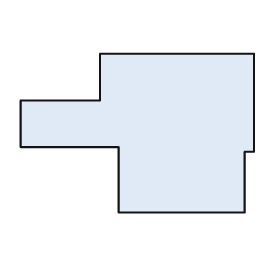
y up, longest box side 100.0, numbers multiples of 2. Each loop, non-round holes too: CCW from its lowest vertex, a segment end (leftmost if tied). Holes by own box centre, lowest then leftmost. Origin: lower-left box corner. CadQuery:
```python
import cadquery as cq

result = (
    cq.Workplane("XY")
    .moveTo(42.0, 0.0)
    .lineTo(96.0, 0.0)
    .lineTo(96.0, 26.0)
    .lineTo(100.0, 26.0)
    .lineTo(100.0, 68.0)
    .lineTo(34.0, 68.0)
    .lineTo(34.0, 48.0)
    .lineTo(0.0, 48.0)
    .lineTo(0.0, 28.0)
    .lineTo(42.0, 28.0)
    .close()
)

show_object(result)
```